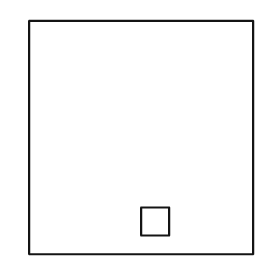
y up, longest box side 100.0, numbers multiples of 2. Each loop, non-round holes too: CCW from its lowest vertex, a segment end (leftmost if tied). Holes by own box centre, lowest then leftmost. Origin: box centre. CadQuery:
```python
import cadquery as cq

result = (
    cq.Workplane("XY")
    .moveTo(-48.0, -50.0)
    .lineTo(48.0, -50.0)
    .lineTo(48.0, 50.0)
    .lineTo(-48.0, 50.0)
    .close()
    .moveTo(0.0, -42.0)
    .lineTo(12.0, -42.0)
    .lineTo(12.0, -30.0)
    .lineTo(0.0, -30.0)
    .close()
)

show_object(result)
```